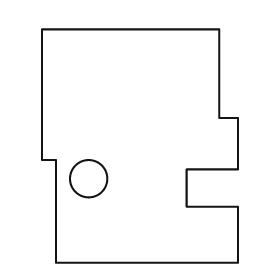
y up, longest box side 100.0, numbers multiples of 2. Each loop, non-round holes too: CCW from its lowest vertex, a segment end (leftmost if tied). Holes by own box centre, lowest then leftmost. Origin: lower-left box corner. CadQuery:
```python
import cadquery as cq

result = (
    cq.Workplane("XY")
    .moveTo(6.0, 0.0)
    .lineTo(84.0, 0.0)
    .lineTo(84.0, 24.0)
    .lineTo(62.0, 24.0)
    .lineTo(62.0, 40.0)
    .lineTo(84.0, 40.0)
    .lineTo(84.0, 62.0)
    .lineTo(76.0, 62.0)
    .lineTo(76.0, 100.0)
    .lineTo(0.0, 100.0)
    .lineTo(0.0, 44.0)
    .lineTo(6.0, 44.0)
    .close()
    .moveTo(20.0, 36.0)
    .circle(8.0)
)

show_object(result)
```